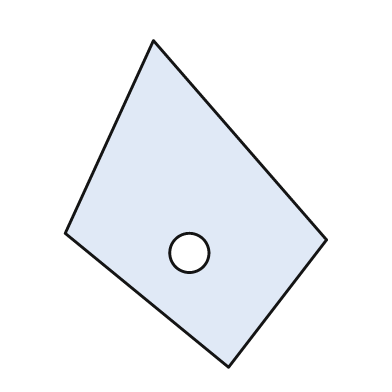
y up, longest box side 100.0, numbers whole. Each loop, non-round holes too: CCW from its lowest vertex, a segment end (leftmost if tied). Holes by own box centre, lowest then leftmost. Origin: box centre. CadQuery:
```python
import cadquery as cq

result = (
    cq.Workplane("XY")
    .moveTo(10.0, -50.0)
    .lineTo(40.0, -11.0)
    .lineTo(-13.0, 50.0)
    .lineTo(-40.0, -9.0)
    .close()
    .moveTo(-2.0, -15.0)
    .circle(6.0)
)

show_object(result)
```